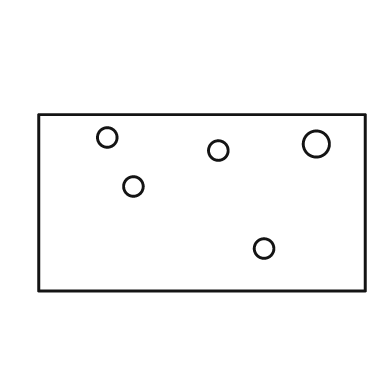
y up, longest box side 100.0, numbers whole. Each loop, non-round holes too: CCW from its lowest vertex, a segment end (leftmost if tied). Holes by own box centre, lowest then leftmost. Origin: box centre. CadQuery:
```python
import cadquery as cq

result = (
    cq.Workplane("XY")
    .moveTo(-50.0, -27.0)
    .lineTo(50.0, -27.0)
    .lineTo(50.0, 27.0)
    .lineTo(-50.0, 27.0)
    .close()
    .moveTo(19.0, -14.0)
    .circle(3.0)
    .moveTo(-21.0, 5.0)
    .circle(3.0)
    .moveTo(5.0, 16.0)
    .circle(3.0)
    .moveTo(35.0, 18.0)
    .circle(4.0)
    .moveTo(-29.0, 20.0)
    .circle(3.0)
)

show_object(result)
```